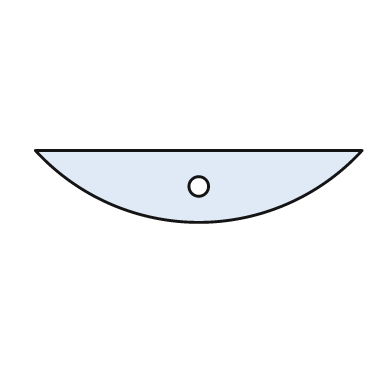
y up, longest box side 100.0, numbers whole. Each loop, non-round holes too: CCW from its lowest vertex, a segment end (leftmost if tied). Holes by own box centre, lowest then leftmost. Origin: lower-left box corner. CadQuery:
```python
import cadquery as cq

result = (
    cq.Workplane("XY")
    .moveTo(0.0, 22.0)
    .threePointArc((50.0, 0.0), (100.0, 22.0))
    .close()
    .moveTo(50.0, 11.0)
    .circle(3.0)
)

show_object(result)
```